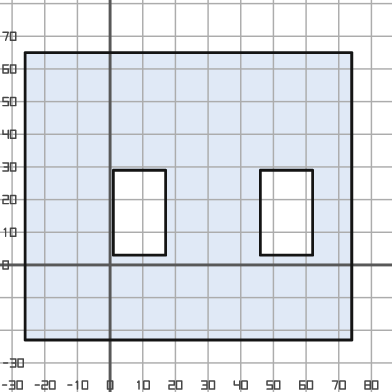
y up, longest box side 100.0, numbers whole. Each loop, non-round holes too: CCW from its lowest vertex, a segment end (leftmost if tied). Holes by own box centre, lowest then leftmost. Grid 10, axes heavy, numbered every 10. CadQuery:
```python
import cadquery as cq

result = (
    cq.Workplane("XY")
    .moveTo(-26.0, -23.0)
    .lineTo(74.0, -23.0)
    .lineTo(74.0, 65.0)
    .lineTo(-26.0, 65.0)
    .close()
    .moveTo(1.0, 3.0)
    .lineTo(17.0, 3.0)
    .lineTo(17.0, 29.0)
    .lineTo(1.0, 29.0)
    .close()
    .moveTo(46.0, 3.0)
    .lineTo(62.0, 3.0)
    .lineTo(62.0, 29.0)
    .lineTo(46.0, 29.0)
    .close()
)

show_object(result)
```